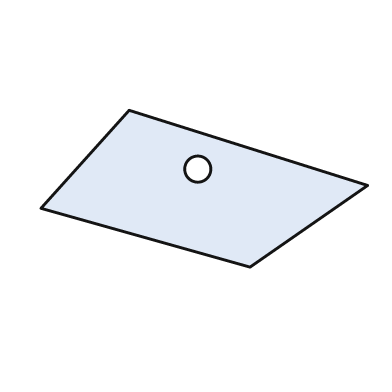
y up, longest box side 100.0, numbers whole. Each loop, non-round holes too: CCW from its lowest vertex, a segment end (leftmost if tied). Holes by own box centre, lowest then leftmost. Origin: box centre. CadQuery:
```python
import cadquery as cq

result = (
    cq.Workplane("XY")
    .moveTo(14.0, -24.0)
    .lineTo(50.0, 1.0)
    .lineTo(-23.0, 24.0)
    .lineTo(-50.0, -6.0)
    .close()
    .moveTo(-2.0, 6.0)
    .circle(4.0)
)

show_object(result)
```